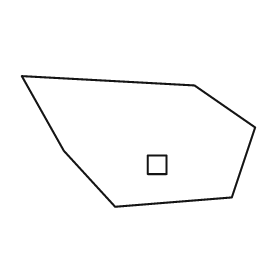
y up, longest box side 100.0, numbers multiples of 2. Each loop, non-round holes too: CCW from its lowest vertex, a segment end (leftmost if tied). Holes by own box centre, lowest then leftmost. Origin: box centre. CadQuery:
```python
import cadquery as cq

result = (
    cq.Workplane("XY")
    .moveTo(-10.0, -28.0)
    .lineTo(40.0, -24.0)
    .lineTo(50.0, 6.0)
    .lineTo(24.0, 24.0)
    .lineTo(-50.0, 28.0)
    .lineTo(-32.0, -4.0)
    .close()
    .moveTo(4.0, -14.0)
    .lineTo(12.0, -14.0)
    .lineTo(12.0, -6.0)
    .lineTo(4.0, -6.0)
    .close()
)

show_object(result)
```